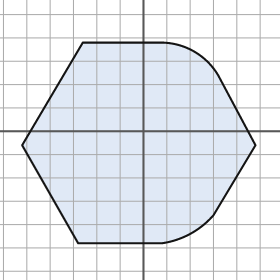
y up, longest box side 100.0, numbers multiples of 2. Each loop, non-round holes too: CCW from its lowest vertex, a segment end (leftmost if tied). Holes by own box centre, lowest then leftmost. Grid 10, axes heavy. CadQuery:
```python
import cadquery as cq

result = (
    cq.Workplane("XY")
    .moveTo(-28.0, -48.0)
    .lineTo(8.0, -48.0)
    .threePointArc((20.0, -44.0), (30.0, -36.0))
    .lineTo(48.0, -6.0)
    .lineTo(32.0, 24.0)
    .threePointArc((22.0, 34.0), (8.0, 38.0))
    .lineTo(-26.0, 38.0)
    .lineTo(-52.0, -6.0)
    .close()
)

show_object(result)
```